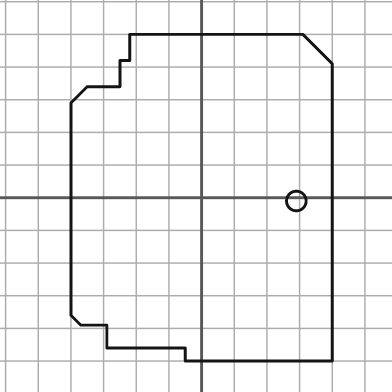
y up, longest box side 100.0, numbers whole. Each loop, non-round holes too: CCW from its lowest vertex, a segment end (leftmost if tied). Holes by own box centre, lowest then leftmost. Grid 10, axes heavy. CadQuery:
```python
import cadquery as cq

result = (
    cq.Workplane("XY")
    .moveTo(-5.0, -50.0)
    .lineTo(40.0, -50.0)
    .lineTo(40.0, 41.0)
    .lineTo(31.0, 50.0)
    .lineTo(-22.0, 50.0)
    .lineTo(-22.0, 42.0)
    .lineTo(-25.0, 42.0)
    .lineTo(-25.0, 34.0)
    .lineTo(-35.0, 34.0)
    .lineTo(-40.0, 29.0)
    .lineTo(-40.0, -36.0)
    .lineTo(-37.0, -39.0)
    .lineTo(-29.0, -39.0)
    .lineTo(-29.0, -46.0)
    .lineTo(-5.0, -46.0)
    .close()
    .moveTo(29.0, -1.0)
    .circle(3.0)
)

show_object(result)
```